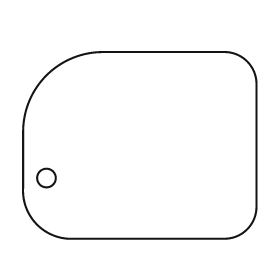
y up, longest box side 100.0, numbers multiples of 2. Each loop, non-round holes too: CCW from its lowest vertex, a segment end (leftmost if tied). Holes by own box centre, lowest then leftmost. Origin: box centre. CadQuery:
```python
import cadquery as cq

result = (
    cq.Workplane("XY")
    .moveTo(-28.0, -40.0)
    .lineTo(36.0, -40.0)
    .threePointArc((46.0, -36.0), (50.0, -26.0))
    .lineTo(50.0, 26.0)
    .threePointArc((46.0, 36.0), (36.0, 40.0))
    .lineTo(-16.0, 40.0)
    .threePointArc((-40.0, 30.0), (-50.0, 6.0))
    .lineTo(-50.0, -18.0)
    .threePointArc((-44.0, -34.0), (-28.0, -40.0))
    .close()
    .moveTo(-40.0, -14.0)
    .circle(4.0)
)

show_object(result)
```